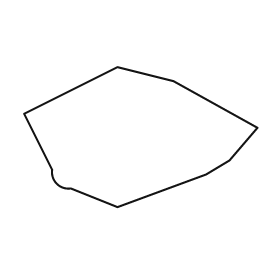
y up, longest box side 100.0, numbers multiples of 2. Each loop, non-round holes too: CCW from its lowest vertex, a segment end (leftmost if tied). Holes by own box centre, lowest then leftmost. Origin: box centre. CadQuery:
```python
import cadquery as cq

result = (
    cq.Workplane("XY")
    .moveTo(-10.0, -30.0)
    .lineTo(28.0, -16.0)
    .lineTo(38.0, -10.0)
    .lineTo(50.0, 4.0)
    .lineTo(14.0, 24.0)
    .lineTo(-10.0, 30.0)
    .lineTo(-50.0, 10.0)
    .lineTo(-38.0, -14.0)
    .threePointArc((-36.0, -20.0), (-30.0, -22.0))
    .close()
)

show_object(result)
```